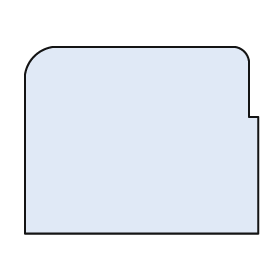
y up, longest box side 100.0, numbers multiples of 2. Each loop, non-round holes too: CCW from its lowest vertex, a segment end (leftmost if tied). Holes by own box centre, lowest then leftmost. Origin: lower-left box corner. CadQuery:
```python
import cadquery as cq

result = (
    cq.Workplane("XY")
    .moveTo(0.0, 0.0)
    .lineTo(100.0, 0.0)
    .lineTo(100.0, 50.0)
    .lineTo(96.0, 50.0)
    .lineTo(96.0, 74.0)
    .threePointArc((94.0, 78.0), (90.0, 80.0))
    .lineTo(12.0, 80.0)
    .threePointArc((4.0, 76.0), (0.0, 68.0))
    .close()
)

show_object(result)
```